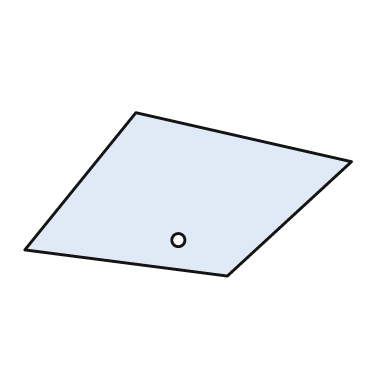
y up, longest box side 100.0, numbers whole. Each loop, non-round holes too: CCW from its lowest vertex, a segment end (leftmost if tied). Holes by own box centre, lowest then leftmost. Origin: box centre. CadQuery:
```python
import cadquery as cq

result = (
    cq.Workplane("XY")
    .moveTo(12.0, -25.0)
    .lineTo(50.0, 10.0)
    .lineTo(-16.0, 25.0)
    .lineTo(-50.0, -17.0)
    .close()
    .moveTo(-3.0, -14.0)
    .circle(2.0)
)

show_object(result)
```